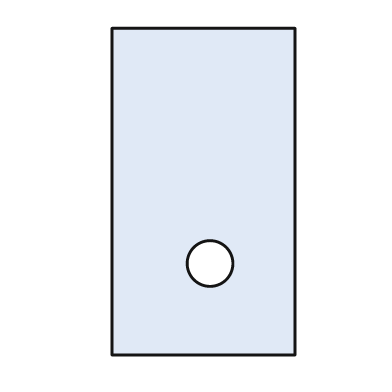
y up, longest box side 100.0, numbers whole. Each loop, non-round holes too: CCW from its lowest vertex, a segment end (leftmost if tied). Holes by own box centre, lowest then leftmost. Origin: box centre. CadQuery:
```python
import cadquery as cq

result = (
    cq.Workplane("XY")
    .moveTo(-28.0, -50.0)
    .lineTo(28.0, -50.0)
    .lineTo(28.0, 50.0)
    .lineTo(-28.0, 50.0)
    .close()
    .moveTo(2.0, -22.0)
    .circle(7.0)
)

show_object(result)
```